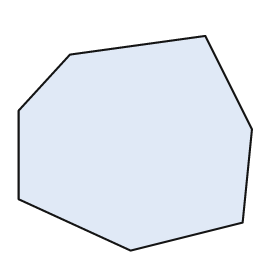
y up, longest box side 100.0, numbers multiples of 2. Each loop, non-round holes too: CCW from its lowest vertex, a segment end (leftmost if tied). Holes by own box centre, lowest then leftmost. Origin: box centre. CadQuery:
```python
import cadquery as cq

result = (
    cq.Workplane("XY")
    .moveTo(-2.0, -46.0)
    .lineTo(46.0, -34.0)
    .lineTo(50.0, 6.0)
    .lineTo(30.0, 46.0)
    .lineTo(-28.0, 38.0)
    .lineTo(-50.0, 14.0)
    .lineTo(-50.0, -24.0)
    .close()
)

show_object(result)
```